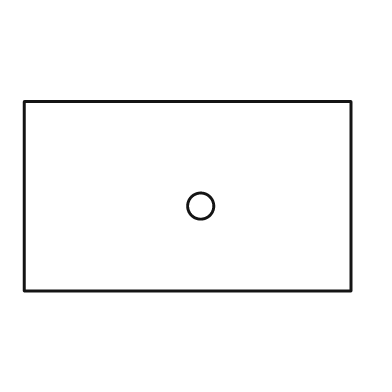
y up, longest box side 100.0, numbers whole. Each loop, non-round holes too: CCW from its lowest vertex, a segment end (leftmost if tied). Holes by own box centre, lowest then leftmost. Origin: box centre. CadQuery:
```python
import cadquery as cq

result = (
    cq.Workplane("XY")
    .moveTo(-50.0, -29.0)
    .lineTo(50.0, -29.0)
    .lineTo(50.0, 29.0)
    .lineTo(-50.0, 29.0)
    .close()
    .moveTo(4.0, -3.0)
    .circle(4.0)
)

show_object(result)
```